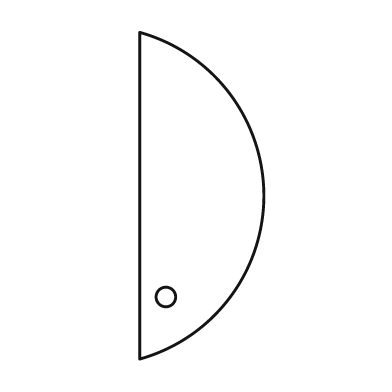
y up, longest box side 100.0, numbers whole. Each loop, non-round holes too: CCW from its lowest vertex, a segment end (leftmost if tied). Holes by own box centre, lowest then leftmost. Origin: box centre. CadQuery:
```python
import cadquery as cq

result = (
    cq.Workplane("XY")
    .moveTo(-19.0, -50.0)
    .threePointArc((19.0, 0.0), (-19.0, 50.0))
    .close()
    .moveTo(-11.0, -31.0)
    .circle(3.0)
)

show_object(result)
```